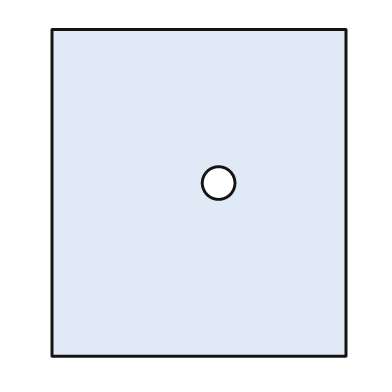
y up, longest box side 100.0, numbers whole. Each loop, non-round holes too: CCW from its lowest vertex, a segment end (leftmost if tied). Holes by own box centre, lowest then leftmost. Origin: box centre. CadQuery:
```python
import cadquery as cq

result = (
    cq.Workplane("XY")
    .moveTo(-45.0, -50.0)
    .lineTo(45.0, -50.0)
    .lineTo(45.0, 50.0)
    .lineTo(-45.0, 50.0)
    .close()
    .moveTo(6.0, 3.0)
    .circle(5.0)
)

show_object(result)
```